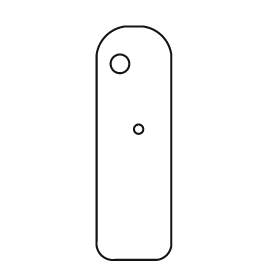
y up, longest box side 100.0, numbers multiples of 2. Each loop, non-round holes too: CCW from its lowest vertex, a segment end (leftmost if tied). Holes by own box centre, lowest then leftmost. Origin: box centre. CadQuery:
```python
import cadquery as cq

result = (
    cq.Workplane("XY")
    .moveTo(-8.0, -50.0)
    .lineTo(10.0, -50.0)
    .threePointArc((14.0, -48.0), (16.0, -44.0))
    .lineTo(16.0, 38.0)
    .threePointArc((12.0, 46.0), (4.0, 50.0))
    .lineTo(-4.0, 50.0)
    .threePointArc((-12.0, 46.0), (-16.0, 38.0))
    .lineTo(-16.0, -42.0)
    .threePointArc((-14.0, -48.0), (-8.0, -50.0))
    .close()
    .moveTo(2.0, 6.0)
    .circle(2.0)
    .moveTo(-6.0, 34.0)
    .circle(4.0)
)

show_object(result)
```